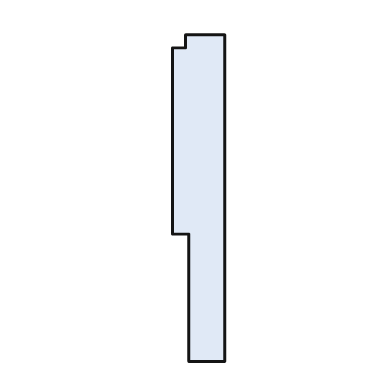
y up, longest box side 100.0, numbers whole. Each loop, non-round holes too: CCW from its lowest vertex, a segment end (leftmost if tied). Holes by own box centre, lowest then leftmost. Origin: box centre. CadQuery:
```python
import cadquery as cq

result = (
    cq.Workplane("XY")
    .moveTo(-3.0, -50.0)
    .lineTo(8.0, -50.0)
    .lineTo(8.0, 50.0)
    .lineTo(-4.0, 50.0)
    .lineTo(-4.0, 46.0)
    .lineTo(-8.0, 46.0)
    .lineTo(-8.0, -11.0)
    .lineTo(-3.0, -11.0)
    .close()
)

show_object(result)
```